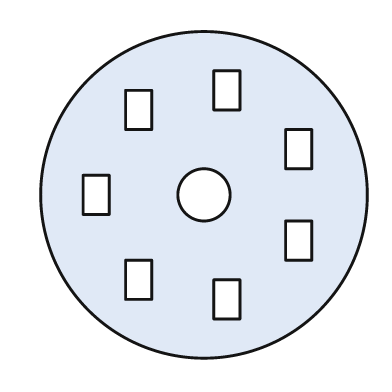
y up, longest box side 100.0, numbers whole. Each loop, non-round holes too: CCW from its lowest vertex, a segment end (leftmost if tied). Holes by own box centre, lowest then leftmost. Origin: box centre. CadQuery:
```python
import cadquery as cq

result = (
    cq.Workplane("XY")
    .moveTo(0.0, 0.0)
    .circle(50.0)
    .moveTo(3.0, -38.0)
    .lineTo(11.0, -38.0)
    .lineTo(11.0, -26.0)
    .lineTo(3.0, -26.0)
    .close()
    .moveTo(-24.0, -32.0)
    .lineTo(-16.0, -32.0)
    .lineTo(-16.0, -20.0)
    .lineTo(-24.0, -20.0)
    .close()
    .moveTo(25.0, -20.0)
    .lineTo(33.0, -20.0)
    .lineTo(33.0, -8.0)
    .lineTo(25.0, -8.0)
    .close()
    .moveTo(-37.0, -6.0)
    .lineTo(-29.0, -6.0)
    .lineTo(-29.0, 6.0)
    .lineTo(-37.0, 6.0)
    .close()
    .moveTo(0.0, 0.0)
    .circle(8.0)
    .moveTo(25.0, 8.0)
    .lineTo(33.0, 8.0)
    .lineTo(33.0, 20.0)
    .lineTo(25.0, 20.0)
    .close()
    .moveTo(-24.0, 20.0)
    .lineTo(-16.0, 20.0)
    .lineTo(-16.0, 32.0)
    .lineTo(-24.0, 32.0)
    .close()
    .moveTo(3.0, 26.0)
    .lineTo(11.0, 26.0)
    .lineTo(11.0, 38.0)
    .lineTo(3.0, 38.0)
    .close()
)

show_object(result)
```